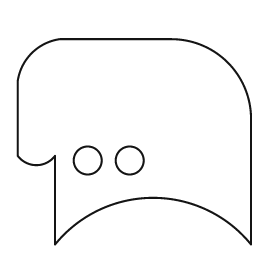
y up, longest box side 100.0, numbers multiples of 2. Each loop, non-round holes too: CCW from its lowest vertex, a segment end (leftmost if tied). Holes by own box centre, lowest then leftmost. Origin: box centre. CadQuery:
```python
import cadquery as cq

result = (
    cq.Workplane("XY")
    .moveTo(-34.0, -44.0)
    .threePointArc((8.0, -24.0), (50.0, -44.0))
    .lineTo(50.0, 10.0)
    .threePointArc((40.0, 34.0), (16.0, 44.0))
    .lineTo(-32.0, 44.0)
    .threePointArc((-44.0, 38.0), (-50.0, 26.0))
    .lineTo(-50.0, -6.0)
    .threePointArc((-42.0, -10.0), (-34.0, -6.0))
    .close()
    .moveTo(-20.0, -8.0)
    .circle(6.0)
    .moveTo(-2.0, -8.0)
    .circle(6.0)
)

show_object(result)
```